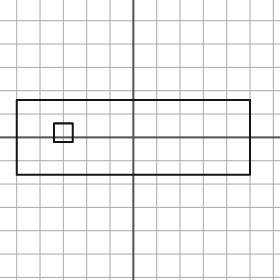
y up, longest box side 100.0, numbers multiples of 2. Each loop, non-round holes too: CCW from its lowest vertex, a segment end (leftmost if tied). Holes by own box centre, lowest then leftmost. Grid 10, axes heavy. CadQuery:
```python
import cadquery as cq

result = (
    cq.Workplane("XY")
    .moveTo(-50.0, -16.0)
    .lineTo(50.0, -16.0)
    .lineTo(50.0, 16.0)
    .lineTo(-50.0, 16.0)
    .close()
    .moveTo(-34.0, -2.0)
    .lineTo(-26.0, -2.0)
    .lineTo(-26.0, 6.0)
    .lineTo(-34.0, 6.0)
    .close()
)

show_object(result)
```